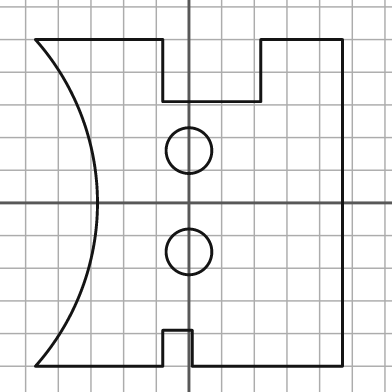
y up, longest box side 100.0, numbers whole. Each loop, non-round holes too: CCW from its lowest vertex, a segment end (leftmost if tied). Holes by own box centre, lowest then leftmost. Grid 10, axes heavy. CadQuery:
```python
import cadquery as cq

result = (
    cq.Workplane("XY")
    .moveTo(-47.0, -50.0)
    .lineTo(-8.0, -50.0)
    .lineTo(-8.0, -39.0)
    .lineTo(1.0, -39.0)
    .lineTo(1.0, -50.0)
    .lineTo(47.0, -50.0)
    .lineTo(47.0, 50.0)
    .lineTo(22.0, 50.0)
    .lineTo(22.0, 31.0)
    .lineTo(-8.0, 31.0)
    .lineTo(-8.0, 50.0)
    .lineTo(-47.0, 50.0)
    .threePointArc((-28.0, 0.0), (-47.0, -50.0))
    .close()
    .moveTo(0.0, -15.0)
    .circle(7.0)
    .moveTo(0.0, 16.0)
    .circle(7.0)
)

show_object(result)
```